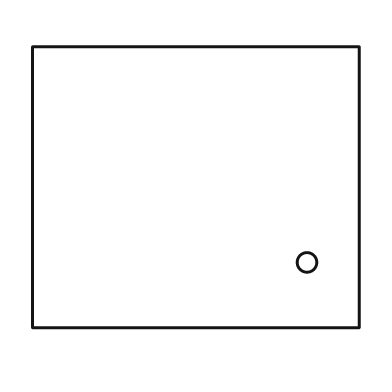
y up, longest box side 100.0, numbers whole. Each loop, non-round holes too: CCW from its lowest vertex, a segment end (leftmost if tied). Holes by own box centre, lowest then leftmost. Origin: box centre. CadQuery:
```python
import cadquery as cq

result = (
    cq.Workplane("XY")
    .moveTo(-50.0, -43.0)
    .lineTo(50.0, -43.0)
    .lineTo(50.0, 43.0)
    .lineTo(-50.0, 43.0)
    .close()
    .moveTo(34.0, -23.0)
    .circle(3.0)
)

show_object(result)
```